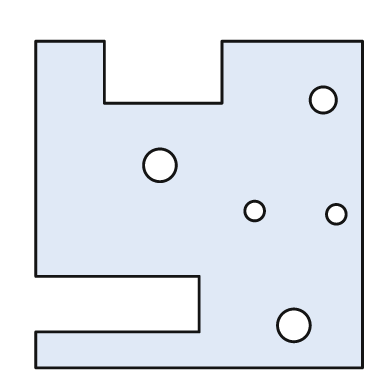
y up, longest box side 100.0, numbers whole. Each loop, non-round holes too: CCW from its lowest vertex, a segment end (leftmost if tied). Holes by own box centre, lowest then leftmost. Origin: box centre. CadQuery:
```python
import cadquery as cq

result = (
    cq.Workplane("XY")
    .moveTo(-50.0, -50.0)
    .lineTo(50.0, -50.0)
    .lineTo(50.0, 50.0)
    .lineTo(7.0, 50.0)
    .lineTo(7.0, 31.0)
    .lineTo(-29.0, 31.0)
    .lineTo(-29.0, 50.0)
    .lineTo(-50.0, 50.0)
    .lineTo(-50.0, -22.0)
    .lineTo(0.0, -22.0)
    .lineTo(0.0, -39.0)
    .lineTo(-50.0, -39.0)
    .close()
    .moveTo(29.0, -37.0)
    .circle(5.0)
    .moveTo(42.0, -3.0)
    .circle(3.0)
    .moveTo(17.0, -2.0)
    .circle(3.0)
    .moveTo(-12.0, 12.0)
    .circle(5.0)
    .moveTo(38.0, 32.0)
    .circle(4.0)
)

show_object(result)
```